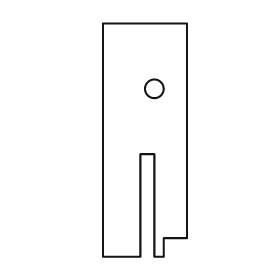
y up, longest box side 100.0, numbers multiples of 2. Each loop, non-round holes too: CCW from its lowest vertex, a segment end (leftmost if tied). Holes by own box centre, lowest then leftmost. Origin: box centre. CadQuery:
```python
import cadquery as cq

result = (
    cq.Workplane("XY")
    .moveTo(-18.0, -50.0)
    .lineTo(-2.0, -50.0)
    .lineTo(-2.0, -6.0)
    .lineTo(4.0, -6.0)
    .lineTo(4.0, -50.0)
    .lineTo(8.0, -50.0)
    .lineTo(8.0, -42.0)
    .lineTo(18.0, -42.0)
    .lineTo(18.0, 50.0)
    .lineTo(-18.0, 50.0)
    .close()
    .moveTo(4.0, 22.0)
    .circle(4.0)
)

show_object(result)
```